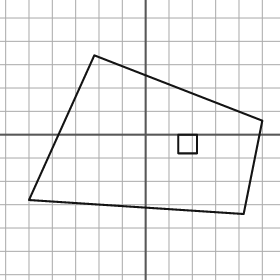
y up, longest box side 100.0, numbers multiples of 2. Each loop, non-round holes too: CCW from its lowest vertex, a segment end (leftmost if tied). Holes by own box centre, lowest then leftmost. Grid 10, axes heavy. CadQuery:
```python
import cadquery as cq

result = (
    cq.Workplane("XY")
    .moveTo(42.0, -34.0)
    .lineTo(50.0, 6.0)
    .lineTo(-22.0, 34.0)
    .lineTo(-50.0, -28.0)
    .close()
    .moveTo(14.0, -8.0)
    .lineTo(22.0, -8.0)
    .lineTo(22.0, 0.0)
    .lineTo(14.0, 0.0)
    .close()
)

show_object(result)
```